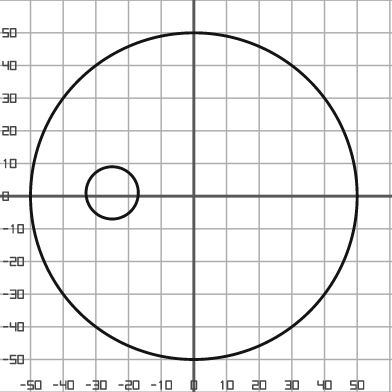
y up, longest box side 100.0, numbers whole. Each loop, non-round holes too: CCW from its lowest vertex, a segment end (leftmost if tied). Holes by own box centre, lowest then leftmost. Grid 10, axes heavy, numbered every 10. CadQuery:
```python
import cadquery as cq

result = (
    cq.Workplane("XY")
    .moveTo(0.0, 0.0)
    .circle(50.0)
    .moveTo(-25.0, 1.0)
    .circle(8.0)
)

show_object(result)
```